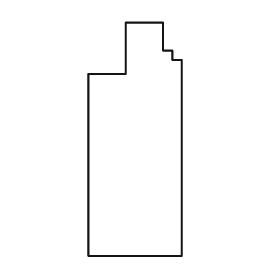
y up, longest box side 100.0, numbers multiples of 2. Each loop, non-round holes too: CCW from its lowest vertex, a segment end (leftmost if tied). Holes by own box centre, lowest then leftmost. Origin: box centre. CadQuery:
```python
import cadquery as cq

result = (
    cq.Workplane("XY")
    .moveTo(-20.0, -50.0)
    .lineTo(20.0, -50.0)
    .lineTo(20.0, 34.0)
    .lineTo(16.0, 34.0)
    .lineTo(16.0, 38.0)
    .lineTo(12.0, 38.0)
    .lineTo(12.0, 50.0)
    .lineTo(-4.0, 50.0)
    .lineTo(-4.0, 28.0)
    .lineTo(-20.0, 28.0)
    .close()
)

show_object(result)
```